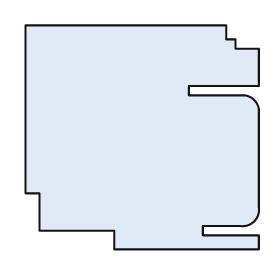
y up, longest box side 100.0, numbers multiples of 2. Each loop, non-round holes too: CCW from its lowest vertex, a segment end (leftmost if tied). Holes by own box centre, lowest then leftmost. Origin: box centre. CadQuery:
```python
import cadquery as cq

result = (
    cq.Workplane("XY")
    .moveTo(-12.0, -48.0)
    .lineTo(50.0, -48.0)
    .lineTo(50.0, -42.0)
    .lineTo(26.0, -42.0)
    .lineTo(26.0, -38.0)
    .lineTo(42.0, -38.0)
    .threePointArc((48.0, -36.0), (50.0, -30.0))
    .lineTo(50.0, 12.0)
    .threePointArc((48.0, 16.0), (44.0, 18.0))
    .lineTo(20.0, 18.0)
    .lineTo(20.0, 22.0)
    .lineTo(50.0, 22.0)
    .lineTo(50.0, 38.0)
    .lineTo(40.0, 38.0)
    .lineTo(40.0, 42.0)
    .lineTo(36.0, 42.0)
    .lineTo(36.0, 48.0)
    .lineTo(-50.0, 48.0)
    .lineTo(-50.0, -24.0)
    .lineTo(-44.0, -24.0)
    .lineTo(-44.0, -40.0)
    .lineTo(-12.0, -40.0)
    .close()
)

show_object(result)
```